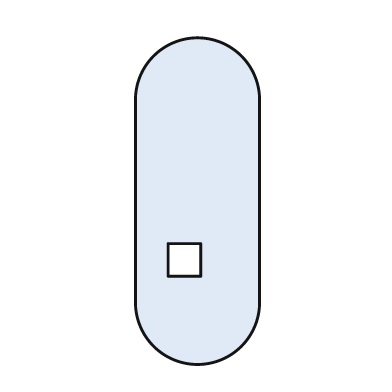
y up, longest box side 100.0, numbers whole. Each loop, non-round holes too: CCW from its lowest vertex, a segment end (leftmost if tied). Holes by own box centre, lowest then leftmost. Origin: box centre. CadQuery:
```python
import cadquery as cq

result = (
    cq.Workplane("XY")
    .moveTo(-19.0, -31.0)
    .threePointArc((0.0, -50.0), (19.0, -31.0))
    .lineTo(19.0, 31.0)
    .threePointArc((0.0, 50.0), (-19.0, 31.0))
    .close()
    .moveTo(-9.0, -23.0)
    .lineTo(1.0, -23.0)
    .lineTo(1.0, -13.0)
    .lineTo(-9.0, -13.0)
    .close()
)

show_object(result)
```